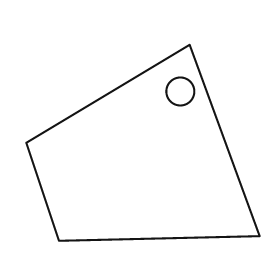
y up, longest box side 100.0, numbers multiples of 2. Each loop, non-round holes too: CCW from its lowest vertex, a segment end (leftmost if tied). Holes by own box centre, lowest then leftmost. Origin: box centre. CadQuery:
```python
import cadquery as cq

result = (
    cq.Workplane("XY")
    .moveTo(-36.0, -42.0)
    .lineTo(50.0, -40.0)
    .lineTo(20.0, 42.0)
    .lineTo(-50.0, 0.0)
    .close()
    .moveTo(16.0, 22.0)
    .circle(6.0)
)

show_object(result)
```